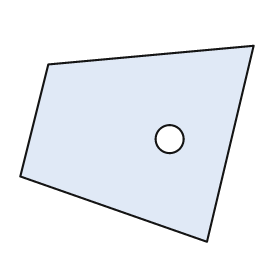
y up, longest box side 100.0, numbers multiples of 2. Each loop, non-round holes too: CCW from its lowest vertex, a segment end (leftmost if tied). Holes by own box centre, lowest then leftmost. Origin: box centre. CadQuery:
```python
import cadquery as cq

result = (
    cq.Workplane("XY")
    .moveTo(30.0, -42.0)
    .lineTo(50.0, 42.0)
    .lineTo(-38.0, 34.0)
    .lineTo(-50.0, -14.0)
    .close()
    .moveTo(14.0, 2.0)
    .circle(6.0)
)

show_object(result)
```